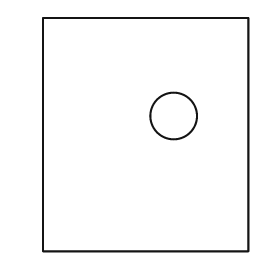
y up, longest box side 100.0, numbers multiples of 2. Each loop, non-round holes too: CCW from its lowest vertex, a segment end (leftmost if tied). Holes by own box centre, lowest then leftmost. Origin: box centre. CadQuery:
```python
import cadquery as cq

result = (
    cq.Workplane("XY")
    .moveTo(-44.0, -50.0)
    .lineTo(44.0, -50.0)
    .lineTo(44.0, 50.0)
    .lineTo(-44.0, 50.0)
    .close()
    .moveTo(12.0, 8.0)
    .circle(10.0)
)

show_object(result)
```